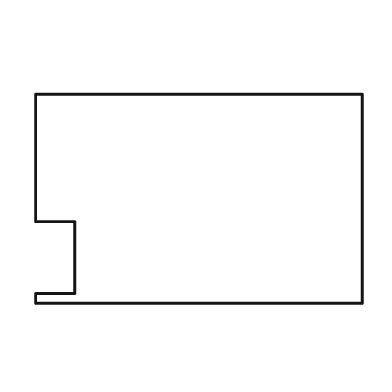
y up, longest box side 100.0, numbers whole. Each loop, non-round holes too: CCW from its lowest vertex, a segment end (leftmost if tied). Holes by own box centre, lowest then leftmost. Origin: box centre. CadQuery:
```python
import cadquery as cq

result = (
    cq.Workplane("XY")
    .moveTo(-50.0, -32.0)
    .lineTo(50.0, -32.0)
    .lineTo(50.0, 32.0)
    .lineTo(-50.0, 32.0)
    .lineTo(-50.0, -7.0)
    .lineTo(-38.0, -7.0)
    .lineTo(-38.0, -29.0)
    .lineTo(-50.0, -29.0)
    .close()
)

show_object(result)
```